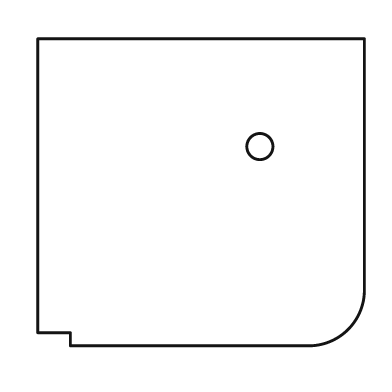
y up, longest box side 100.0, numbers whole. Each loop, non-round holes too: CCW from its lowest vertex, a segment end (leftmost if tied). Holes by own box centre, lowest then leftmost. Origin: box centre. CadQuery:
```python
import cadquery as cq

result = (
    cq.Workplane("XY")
    .moveTo(-40.0, -47.0)
    .lineTo(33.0, -47.0)
    .threePointArc((45.0, -42.0), (50.0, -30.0))
    .lineTo(50.0, 47.0)
    .lineTo(-50.0, 47.0)
    .lineTo(-50.0, -43.0)
    .lineTo(-40.0, -43.0)
    .close()
    .moveTo(18.0, 14.0)
    .circle(4.0)
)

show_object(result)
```